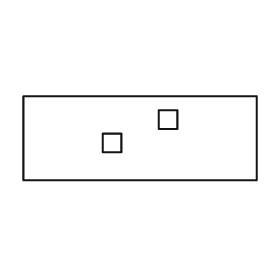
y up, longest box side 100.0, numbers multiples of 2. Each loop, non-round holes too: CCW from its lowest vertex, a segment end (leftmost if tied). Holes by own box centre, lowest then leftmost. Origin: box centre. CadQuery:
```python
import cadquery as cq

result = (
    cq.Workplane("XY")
    .moveTo(-50.0, -18.0)
    .lineTo(50.0, -18.0)
    .lineTo(50.0, 18.0)
    .lineTo(-50.0, 18.0)
    .close()
    .moveTo(-16.0, -6.0)
    .lineTo(-8.0, -6.0)
    .lineTo(-8.0, 2.0)
    .lineTo(-16.0, 2.0)
    .close()
    .moveTo(8.0, 4.0)
    .lineTo(16.0, 4.0)
    .lineTo(16.0, 12.0)
    .lineTo(8.0, 12.0)
    .close()
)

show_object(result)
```